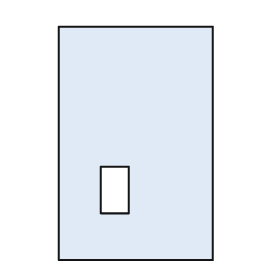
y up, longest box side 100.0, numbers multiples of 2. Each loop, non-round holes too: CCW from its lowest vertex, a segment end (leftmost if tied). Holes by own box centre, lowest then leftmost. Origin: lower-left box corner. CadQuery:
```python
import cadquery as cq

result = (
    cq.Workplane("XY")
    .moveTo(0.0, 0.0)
    .lineTo(66.0, 0.0)
    .lineTo(66.0, 100.0)
    .lineTo(0.0, 100.0)
    .close()
    .moveTo(18.0, 20.0)
    .lineTo(30.0, 20.0)
    .lineTo(30.0, 40.0)
    .lineTo(18.0, 40.0)
    .close()
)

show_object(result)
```